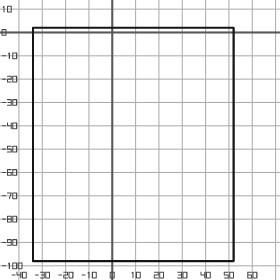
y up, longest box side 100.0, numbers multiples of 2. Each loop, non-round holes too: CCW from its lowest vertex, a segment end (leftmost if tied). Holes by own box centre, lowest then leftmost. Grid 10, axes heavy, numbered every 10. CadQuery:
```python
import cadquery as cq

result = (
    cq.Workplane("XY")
    .moveTo(-34.0, -98.0)
    .lineTo(52.0, -98.0)
    .lineTo(52.0, 2.0)
    .lineTo(-34.0, 2.0)
    .close()
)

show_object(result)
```